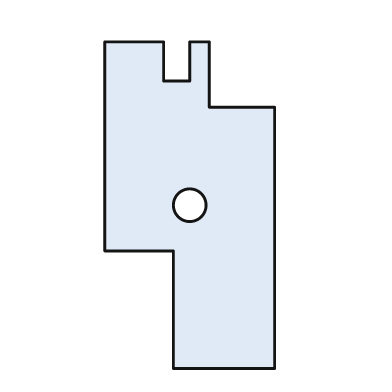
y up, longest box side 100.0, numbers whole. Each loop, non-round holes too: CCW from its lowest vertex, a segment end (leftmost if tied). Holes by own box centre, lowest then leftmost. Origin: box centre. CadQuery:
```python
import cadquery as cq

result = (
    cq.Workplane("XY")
    .moveTo(-5.0, -50.0)
    .lineTo(26.0, -50.0)
    .lineTo(26.0, 30.0)
    .lineTo(6.0, 30.0)
    .lineTo(6.0, 50.0)
    .lineTo(0.0, 50.0)
    .lineTo(0.0, 38.0)
    .lineTo(-8.0, 38.0)
    .lineTo(-8.0, 50.0)
    .lineTo(-26.0, 50.0)
    .lineTo(-26.0, -14.0)
    .lineTo(-5.0, -14.0)
    .close()
    .moveTo(0.0, 0.0)
    .circle(5.0)
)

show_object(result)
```